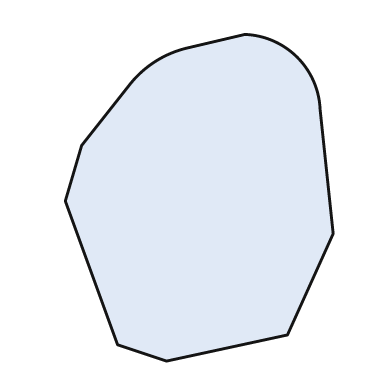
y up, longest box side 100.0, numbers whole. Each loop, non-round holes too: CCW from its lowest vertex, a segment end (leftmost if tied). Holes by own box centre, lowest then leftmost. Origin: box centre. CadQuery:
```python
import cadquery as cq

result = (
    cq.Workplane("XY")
    .moveTo(-10.0, -50.0)
    .lineTo(27.0, -42.0)
    .lineTo(41.0, -11.0)
    .lineTo(37.0, 27.0)
    .threePointArc((30.0, 43.0), (14.0, 50.0))
    .lineTo(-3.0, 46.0)
    .threePointArc((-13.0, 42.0), (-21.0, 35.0))
    .lineTo(-36.0, 16.0)
    .lineTo(-41.0, -1.0)
    .lineTo(-25.0, -45.0)
    .close()
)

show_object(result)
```